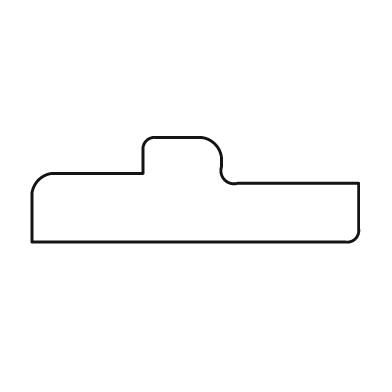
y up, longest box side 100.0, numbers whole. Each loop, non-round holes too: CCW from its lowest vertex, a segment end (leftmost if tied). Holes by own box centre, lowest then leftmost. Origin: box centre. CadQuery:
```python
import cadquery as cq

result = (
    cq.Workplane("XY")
    .moveTo(-50.0, -16.0)
    .lineTo(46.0, -16.0)
    .threePointArc((49.0, -15.0), (50.0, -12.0))
    .lineTo(50.0, 2.0)
    .lineTo(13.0, 2.0)
    .threePointArc((9.0, 3.0), (8.0, 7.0))
    .lineTo(8.0, 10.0)
    .threePointArc((6.0, 14.0), (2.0, 16.0))
    .lineTo(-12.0, 16.0)
    .threePointArc((-15.0, 15.0), (-16.0, 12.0))
    .lineTo(-16.0, 5.0)
    .lineTo(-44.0, 5.0)
    .threePointArc((-48.0, 3.0), (-50.0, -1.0))
    .close()
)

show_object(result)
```